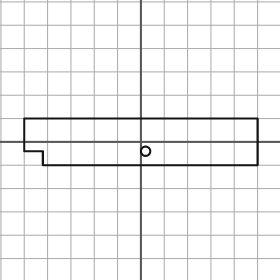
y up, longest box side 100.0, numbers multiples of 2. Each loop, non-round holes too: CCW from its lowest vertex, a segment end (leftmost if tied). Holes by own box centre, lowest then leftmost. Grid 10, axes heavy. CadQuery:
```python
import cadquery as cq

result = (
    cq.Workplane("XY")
    .moveTo(-42.0, -10.0)
    .lineTo(50.0, -10.0)
    .lineTo(50.0, 10.0)
    .lineTo(-50.0, 10.0)
    .lineTo(-50.0, -4.0)
    .lineTo(-42.0, -4.0)
    .close()
    .moveTo(2.0, -4.0)
    .circle(2.0)
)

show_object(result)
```